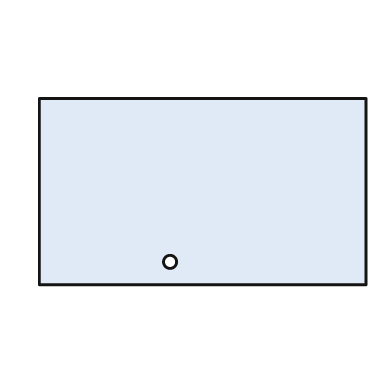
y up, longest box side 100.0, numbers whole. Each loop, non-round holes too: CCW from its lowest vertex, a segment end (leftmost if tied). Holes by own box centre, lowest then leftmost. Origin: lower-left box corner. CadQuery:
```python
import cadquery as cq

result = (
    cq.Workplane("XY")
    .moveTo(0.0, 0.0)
    .lineTo(100.0, 0.0)
    .lineTo(100.0, 57.0)
    .lineTo(0.0, 57.0)
    .close()
    .moveTo(40.0, 7.0)
    .circle(2.0)
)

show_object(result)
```